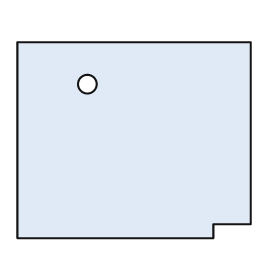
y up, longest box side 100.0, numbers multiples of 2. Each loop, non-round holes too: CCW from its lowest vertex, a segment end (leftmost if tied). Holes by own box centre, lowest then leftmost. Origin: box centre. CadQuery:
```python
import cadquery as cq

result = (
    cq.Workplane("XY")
    .moveTo(-50.0, -42.0)
    .lineTo(34.0, -42.0)
    .lineTo(34.0, -36.0)
    .lineTo(50.0, -36.0)
    .lineTo(50.0, 42.0)
    .lineTo(-50.0, 42.0)
    .close()
    .moveTo(-20.0, 24.0)
    .circle(4.0)
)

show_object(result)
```